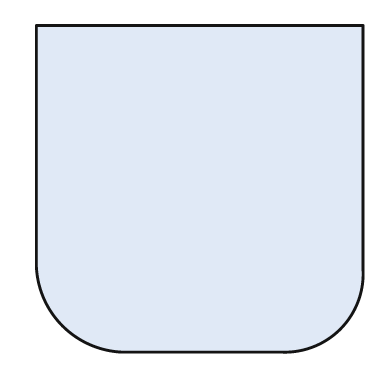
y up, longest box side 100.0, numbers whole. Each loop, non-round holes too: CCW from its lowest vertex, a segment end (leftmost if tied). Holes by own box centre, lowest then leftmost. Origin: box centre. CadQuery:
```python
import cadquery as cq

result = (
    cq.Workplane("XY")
    .moveTo(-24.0, -50.0)
    .lineTo(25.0, -50.0)
    .threePointArc((43.0, -43.0), (50.0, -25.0))
    .lineTo(50.0, 50.0)
    .lineTo(-50.0, 50.0)
    .lineTo(-50.0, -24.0)
    .threePointArc((-42.0, -42.0), (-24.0, -50.0))
    .close()
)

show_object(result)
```